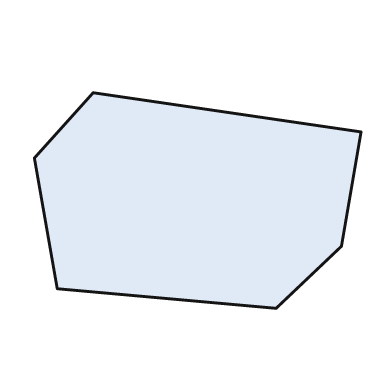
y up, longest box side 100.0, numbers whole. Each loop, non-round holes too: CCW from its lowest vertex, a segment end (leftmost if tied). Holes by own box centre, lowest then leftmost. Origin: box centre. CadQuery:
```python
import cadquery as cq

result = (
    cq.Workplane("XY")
    .moveTo(24.0, -33.0)
    .lineTo(44.0, -14.0)
    .lineTo(50.0, 21.0)
    .lineTo(-32.0, 33.0)
    .lineTo(-50.0, 13.0)
    .lineTo(-43.0, -27.0)
    .close()
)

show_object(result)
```